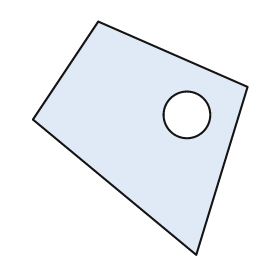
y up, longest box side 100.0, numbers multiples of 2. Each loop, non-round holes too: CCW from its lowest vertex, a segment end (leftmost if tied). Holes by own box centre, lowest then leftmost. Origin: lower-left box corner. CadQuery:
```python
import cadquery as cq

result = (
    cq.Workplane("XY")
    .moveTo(70.0, 0.0)
    .lineTo(92.0, 72.0)
    .lineTo(28.0, 100.0)
    .lineTo(0.0, 58.0)
    .close()
    .moveTo(66.0, 60.0)
    .circle(10.0)
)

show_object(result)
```